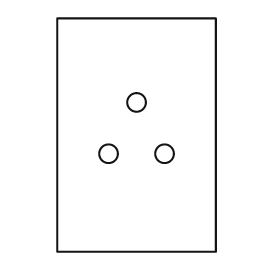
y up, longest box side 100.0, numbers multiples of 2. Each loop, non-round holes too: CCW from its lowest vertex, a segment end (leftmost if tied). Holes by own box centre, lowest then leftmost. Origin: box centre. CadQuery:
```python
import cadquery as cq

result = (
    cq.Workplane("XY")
    .moveTo(-34.0, -50.0)
    .lineTo(34.0, -50.0)
    .lineTo(34.0, 50.0)
    .lineTo(-34.0, 50.0)
    .close()
    .moveTo(-12.0, -8.0)
    .circle(4.0)
    .moveTo(12.0, -8.0)
    .circle(4.0)
    .moveTo(0.0, 14.0)
    .circle(4.0)
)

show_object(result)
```